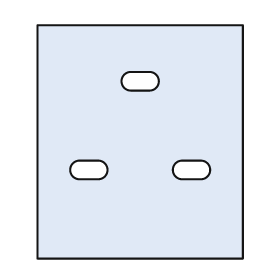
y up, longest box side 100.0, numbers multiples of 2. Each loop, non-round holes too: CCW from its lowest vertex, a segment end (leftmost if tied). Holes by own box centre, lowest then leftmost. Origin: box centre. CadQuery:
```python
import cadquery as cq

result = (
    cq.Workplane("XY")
    .moveTo(-44.0, -50.0)
    .lineTo(44.0, -50.0)
    .lineTo(44.0, 50.0)
    .lineTo(-44.0, 50.0)
    .close()
    .moveTo(-26.0, -16.0)
    .lineTo(-18.0, -16.0)
    .threePointArc((-14.0, -12.0), (-18.0, -8.0))
    .lineTo(-26.0, -8.0)
    .threePointArc((-30.0, -12.0), (-26.0, -16.0))
    .close()
    .moveTo(18.0, -16.0)
    .lineTo(26.0, -16.0)
    .threePointArc((30.0, -12.0), (26.0, -8.0))
    .lineTo(18.0, -8.0)
    .threePointArc((14.0, -12.0), (18.0, -16.0))
    .close()
    .moveTo(-4.0, 22.0)
    .lineTo(4.0, 22.0)
    .threePointArc((8.0, 26.0), (4.0, 30.0))
    .lineTo(-4.0, 30.0)
    .threePointArc((-8.0, 26.0), (-4.0, 22.0))
    .close()
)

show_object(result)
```